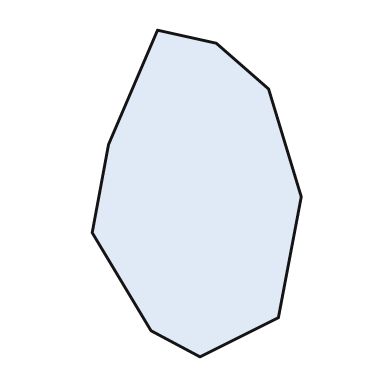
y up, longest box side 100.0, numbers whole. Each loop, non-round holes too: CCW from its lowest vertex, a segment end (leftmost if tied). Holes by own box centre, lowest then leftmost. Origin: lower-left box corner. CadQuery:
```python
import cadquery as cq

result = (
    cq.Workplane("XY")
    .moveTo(33.0, 0.0)
    .lineTo(57.0, 12.0)
    .lineTo(64.0, 49.0)
    .lineTo(54.0, 82.0)
    .lineTo(38.0, 96.0)
    .lineTo(20.0, 100.0)
    .lineTo(5.0, 65.0)
    .lineTo(0.0, 38.0)
    .lineTo(18.0, 8.0)
    .close()
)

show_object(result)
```